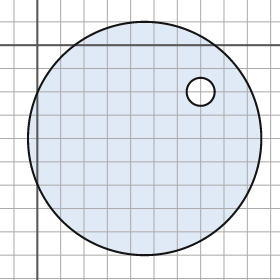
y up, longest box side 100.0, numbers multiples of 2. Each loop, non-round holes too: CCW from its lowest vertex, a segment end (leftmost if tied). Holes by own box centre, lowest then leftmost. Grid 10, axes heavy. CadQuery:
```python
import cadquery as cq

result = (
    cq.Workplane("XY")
    .moveTo(46.0, -40.0)
    .circle(50.0)
    .moveTo(70.0, -20.0)
    .circle(6.0)
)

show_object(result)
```